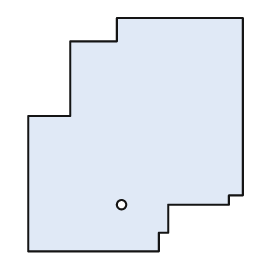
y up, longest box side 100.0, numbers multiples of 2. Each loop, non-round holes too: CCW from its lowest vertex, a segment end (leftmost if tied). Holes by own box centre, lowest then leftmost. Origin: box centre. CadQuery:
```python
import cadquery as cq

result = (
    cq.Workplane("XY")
    .moveTo(-46.0, -50.0)
    .lineTo(10.0, -50.0)
    .lineTo(10.0, -42.0)
    .lineTo(14.0, -42.0)
    .lineTo(14.0, -30.0)
    .lineTo(40.0, -30.0)
    .lineTo(40.0, -26.0)
    .lineTo(46.0, -26.0)
    .lineTo(46.0, 50.0)
    .lineTo(-8.0, 50.0)
    .lineTo(-8.0, 40.0)
    .lineTo(-28.0, 40.0)
    .lineTo(-28.0, 8.0)
    .lineTo(-46.0, 8.0)
    .close()
    .moveTo(-6.0, -30.0)
    .circle(2.0)
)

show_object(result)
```